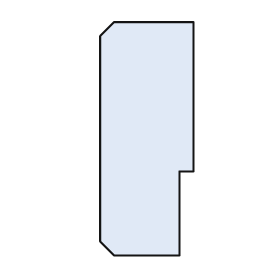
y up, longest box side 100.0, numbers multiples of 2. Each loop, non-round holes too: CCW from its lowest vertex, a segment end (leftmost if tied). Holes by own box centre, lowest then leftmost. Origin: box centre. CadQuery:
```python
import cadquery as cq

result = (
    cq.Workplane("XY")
    .moveTo(-14.0, -50.0)
    .lineTo(14.0, -50.0)
    .lineTo(14.0, -14.0)
    .lineTo(20.0, -14.0)
    .lineTo(20.0, 50.0)
    .lineTo(-14.0, 50.0)
    .lineTo(-20.0, 44.0)
    .lineTo(-20.0, -44.0)
    .close()
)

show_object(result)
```